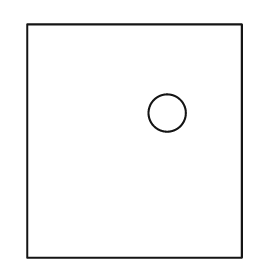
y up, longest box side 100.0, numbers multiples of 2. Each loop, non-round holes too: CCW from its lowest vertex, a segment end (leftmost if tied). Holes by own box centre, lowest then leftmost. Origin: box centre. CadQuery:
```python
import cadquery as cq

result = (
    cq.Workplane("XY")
    .moveTo(-46.0, -50.0)
    .lineTo(46.0, -50.0)
    .lineTo(46.0, 50.0)
    .lineTo(-46.0, 50.0)
    .close()
    .moveTo(14.0, 12.0)
    .circle(8.0)
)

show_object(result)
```